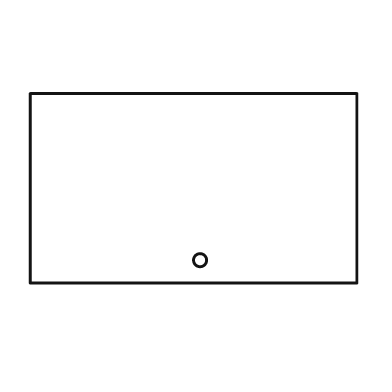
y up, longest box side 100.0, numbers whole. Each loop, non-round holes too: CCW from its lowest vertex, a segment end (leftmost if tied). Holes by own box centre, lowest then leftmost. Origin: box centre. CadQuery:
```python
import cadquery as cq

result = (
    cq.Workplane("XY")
    .moveTo(-50.0, -29.0)
    .lineTo(50.0, -29.0)
    .lineTo(50.0, 29.0)
    .lineTo(-50.0, 29.0)
    .close()
    .moveTo(2.0, -22.0)
    .circle(2.0)
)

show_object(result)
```